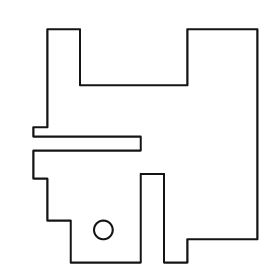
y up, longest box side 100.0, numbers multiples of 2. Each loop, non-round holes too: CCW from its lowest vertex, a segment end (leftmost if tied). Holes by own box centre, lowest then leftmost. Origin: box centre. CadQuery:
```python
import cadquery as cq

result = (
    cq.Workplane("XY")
    .moveTo(-32.0, -50.0)
    .lineTo(-2.0, -50.0)
    .lineTo(-2.0, -12.0)
    .lineTo(8.0, -12.0)
    .lineTo(8.0, -50.0)
    .lineTo(18.0, -50.0)
    .lineTo(18.0, -40.0)
    .lineTo(48.0, -40.0)
    .lineTo(48.0, 50.0)
    .lineTo(18.0, 50.0)
    .lineTo(18.0, 26.0)
    .lineTo(-28.0, 26.0)
    .lineTo(-28.0, 50.0)
    .lineTo(-42.0, 50.0)
    .lineTo(-42.0, 8.0)
    .lineTo(-48.0, 8.0)
    .lineTo(-48.0, 4.0)
    .lineTo(-2.0, 4.0)
    .lineTo(-2.0, -2.0)
    .lineTo(-48.0, -2.0)
    .lineTo(-48.0, -14.0)
    .lineTo(-42.0, -14.0)
    .lineTo(-42.0, -32.0)
    .lineTo(-32.0, -32.0)
    .close()
    .moveTo(-18.0, -36.0)
    .circle(4.0)
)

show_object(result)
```